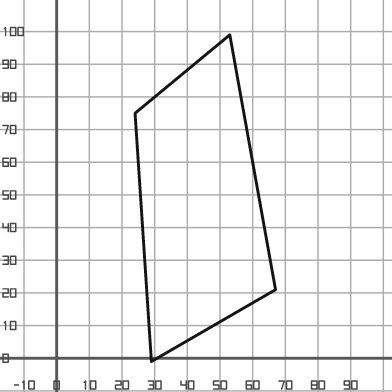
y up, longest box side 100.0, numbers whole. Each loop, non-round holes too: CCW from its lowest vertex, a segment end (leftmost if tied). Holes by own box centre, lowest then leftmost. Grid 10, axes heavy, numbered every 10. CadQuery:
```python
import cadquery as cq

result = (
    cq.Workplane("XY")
    .moveTo(29.0, -1.0)
    .lineTo(67.0, 21.0)
    .lineTo(53.0, 99.0)
    .lineTo(24.0, 75.0)
    .close()
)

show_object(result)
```